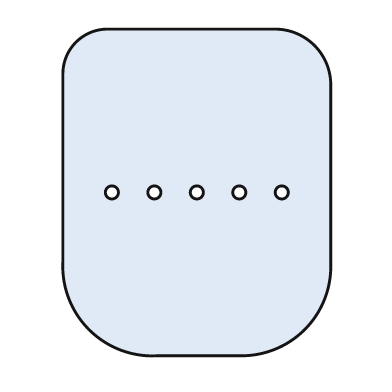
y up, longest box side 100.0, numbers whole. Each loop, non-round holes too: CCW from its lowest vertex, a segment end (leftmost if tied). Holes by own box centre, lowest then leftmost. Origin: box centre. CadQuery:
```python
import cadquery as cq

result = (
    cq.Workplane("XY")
    .moveTo(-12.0, -50.0)
    .lineTo(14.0, -50.0)
    .threePointArc((33.0, -42.0), (41.0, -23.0))
    .lineTo(41.0, 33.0)
    .threePointArc((36.0, 45.0), (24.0, 50.0))
    .lineTo(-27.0, 50.0)
    .threePointArc((-37.0, 46.0), (-41.0, 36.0))
    .lineTo(-41.0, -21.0)
    .threePointArc((-33.0, -42.0), (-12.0, -50.0))
    .close()
    .moveTo(-26.0, 0.0)
    .circle(2.0)
    .moveTo(-13.0, 0.0)
    .circle(2.0)
    .moveTo(0.0, 0.0)
    .circle(2.0)
    .moveTo(13.0, 0.0)
    .circle(2.0)
    .moveTo(26.0, 0.0)
    .circle(2.0)
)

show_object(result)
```